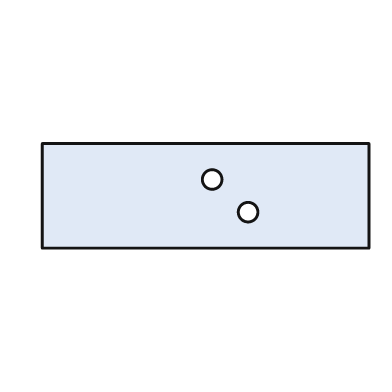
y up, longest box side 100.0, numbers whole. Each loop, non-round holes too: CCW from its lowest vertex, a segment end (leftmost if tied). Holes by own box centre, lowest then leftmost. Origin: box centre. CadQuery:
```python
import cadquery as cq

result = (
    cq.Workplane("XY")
    .moveTo(-50.0, -16.0)
    .lineTo(50.0, -16.0)
    .lineTo(50.0, 16.0)
    .lineTo(-50.0, 16.0)
    .close()
    .moveTo(13.0, -5.0)
    .circle(3.0)
    .moveTo(2.0, 5.0)
    .circle(3.0)
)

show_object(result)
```